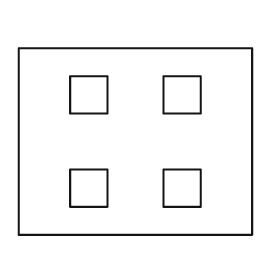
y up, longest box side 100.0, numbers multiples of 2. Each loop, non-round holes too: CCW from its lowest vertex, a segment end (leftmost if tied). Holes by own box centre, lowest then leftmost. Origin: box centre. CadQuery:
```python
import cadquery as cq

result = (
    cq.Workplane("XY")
    .moveTo(-50.0, -40.0)
    .lineTo(50.0, -40.0)
    .lineTo(50.0, 40.0)
    .lineTo(-50.0, 40.0)
    .close()
    .moveTo(-28.0, -28.0)
    .lineTo(-12.0, -28.0)
    .lineTo(-12.0, -12.0)
    .lineTo(-28.0, -12.0)
    .close()
    .moveTo(12.0, -28.0)
    .lineTo(28.0, -28.0)
    .lineTo(28.0, -12.0)
    .lineTo(12.0, -12.0)
    .close()
    .moveTo(-28.0, 12.0)
    .lineTo(-12.0, 12.0)
    .lineTo(-12.0, 28.0)
    .lineTo(-28.0, 28.0)
    .close()
    .moveTo(12.0, 12.0)
    .lineTo(28.0, 12.0)
    .lineTo(28.0, 28.0)
    .lineTo(12.0, 28.0)
    .close()
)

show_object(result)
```